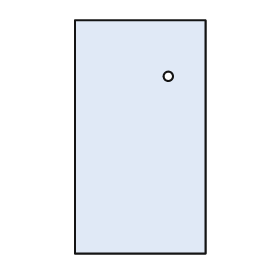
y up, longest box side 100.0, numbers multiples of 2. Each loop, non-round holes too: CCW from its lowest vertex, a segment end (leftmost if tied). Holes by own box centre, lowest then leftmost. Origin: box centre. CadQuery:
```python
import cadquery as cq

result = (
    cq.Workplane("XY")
    .moveTo(-28.0, -50.0)
    .lineTo(28.0, -50.0)
    .lineTo(28.0, 50.0)
    .lineTo(-28.0, 50.0)
    .close()
    .moveTo(12.0, 26.0)
    .circle(2.0)
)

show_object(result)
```